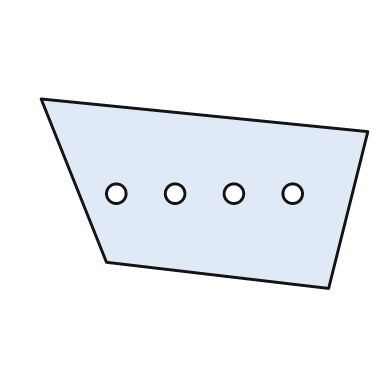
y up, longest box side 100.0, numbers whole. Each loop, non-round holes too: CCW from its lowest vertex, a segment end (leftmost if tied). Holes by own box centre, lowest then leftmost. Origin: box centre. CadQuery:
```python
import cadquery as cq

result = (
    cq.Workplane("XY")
    .moveTo(38.0, -29.0)
    .lineTo(50.0, 19.0)
    .lineTo(-50.0, 29.0)
    .lineTo(-30.0, -21.0)
    .close()
    .moveTo(-27.0, 0.0)
    .circle(3.0)
    .moveTo(-9.0, 0.0)
    .circle(3.0)
    .moveTo(9.0, 0.0)
    .circle(3.0)
    .moveTo(27.0, 0.0)
    .circle(3.0)
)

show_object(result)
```